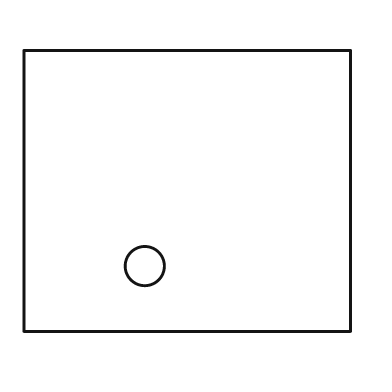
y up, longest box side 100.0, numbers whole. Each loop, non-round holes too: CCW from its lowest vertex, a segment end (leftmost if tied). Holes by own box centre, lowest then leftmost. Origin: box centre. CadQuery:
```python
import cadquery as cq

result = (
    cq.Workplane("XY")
    .moveTo(-50.0, -43.0)
    .lineTo(50.0, -43.0)
    .lineTo(50.0, 43.0)
    .lineTo(-50.0, 43.0)
    .close()
    .moveTo(-13.0, -23.0)
    .circle(6.0)
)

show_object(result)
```